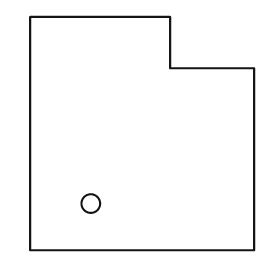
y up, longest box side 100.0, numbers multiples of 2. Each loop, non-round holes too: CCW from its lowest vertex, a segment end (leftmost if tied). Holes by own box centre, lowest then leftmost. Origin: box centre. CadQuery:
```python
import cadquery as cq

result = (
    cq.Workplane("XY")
    .moveTo(-48.0, -50.0)
    .lineTo(48.0, -50.0)
    .lineTo(48.0, 28.0)
    .lineTo(12.0, 28.0)
    .lineTo(12.0, 50.0)
    .lineTo(-48.0, 50.0)
    .close()
    .moveTo(-22.0, -30.0)
    .circle(4.0)
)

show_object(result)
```